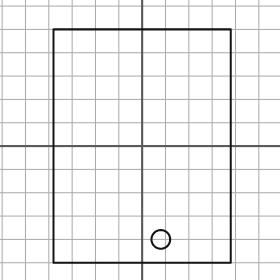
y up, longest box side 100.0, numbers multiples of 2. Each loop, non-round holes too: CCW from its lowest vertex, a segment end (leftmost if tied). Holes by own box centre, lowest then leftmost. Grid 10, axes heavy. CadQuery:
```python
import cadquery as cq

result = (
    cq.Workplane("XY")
    .moveTo(-38.0, -50.0)
    .lineTo(38.0, -50.0)
    .lineTo(38.0, 50.0)
    .lineTo(-38.0, 50.0)
    .close()
    .moveTo(8.0, -40.0)
    .circle(4.0)
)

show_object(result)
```